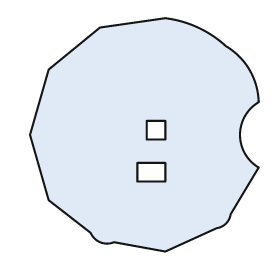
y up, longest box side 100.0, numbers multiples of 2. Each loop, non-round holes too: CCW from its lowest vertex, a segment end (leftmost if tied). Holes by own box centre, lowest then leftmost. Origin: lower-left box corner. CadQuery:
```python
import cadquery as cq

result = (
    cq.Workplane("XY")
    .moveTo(58.0, 0.0)
    .lineTo(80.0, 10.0)
    .threePointArc((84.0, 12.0), (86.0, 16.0))
    .lineTo(98.0, 36.0)
    .threePointArc((90.0, 50.0), (98.0, 64.0))
    .threePointArc((94.0, 78.0), (84.0, 88.0))
    .threePointArc((72.0, 96.0), (58.0, 100.0))
    .lineTo(30.0, 96.0)
    .lineTo(8.0, 78.0)
    .lineTo(0.0, 50.0)
    .lineTo(8.0, 22.0)
    .lineTo(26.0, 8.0)
    .threePointArc((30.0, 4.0), (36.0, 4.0))
    .close()
    .moveTo(46.0, 30.0)
    .lineTo(58.0, 30.0)
    .lineTo(58.0, 38.0)
    .lineTo(46.0, 38.0)
    .close()
    .moveTo(50.0, 48.0)
    .lineTo(58.0, 48.0)
    .lineTo(58.0, 56.0)
    .lineTo(50.0, 56.0)
    .close()
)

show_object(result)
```